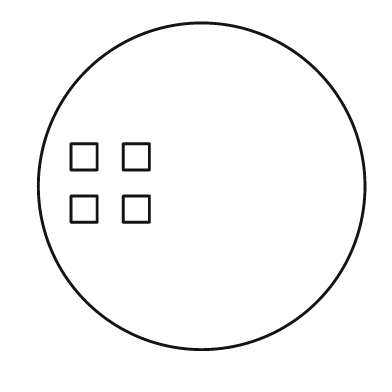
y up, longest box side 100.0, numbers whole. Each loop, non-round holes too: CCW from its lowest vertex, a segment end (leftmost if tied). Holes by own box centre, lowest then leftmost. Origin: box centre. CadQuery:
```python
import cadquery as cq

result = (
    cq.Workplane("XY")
    .moveTo(0.0, 0.0)
    .circle(50.0)
    .moveTo(-40.0, -11.0)
    .lineTo(-32.0, -11.0)
    .lineTo(-32.0, -3.0)
    .lineTo(-40.0, -3.0)
    .close()
    .moveTo(-24.0, -11.0)
    .lineTo(-16.0, -11.0)
    .lineTo(-16.0, -3.0)
    .lineTo(-24.0, -3.0)
    .close()
    .moveTo(-40.0, 5.0)
    .lineTo(-32.0, 5.0)
    .lineTo(-32.0, 13.0)
    .lineTo(-40.0, 13.0)
    .close()
    .moveTo(-24.0, 5.0)
    .lineTo(-16.0, 5.0)
    .lineTo(-16.0, 13.0)
    .lineTo(-24.0, 13.0)
    .close()
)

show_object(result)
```